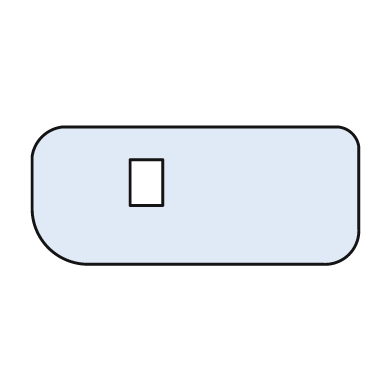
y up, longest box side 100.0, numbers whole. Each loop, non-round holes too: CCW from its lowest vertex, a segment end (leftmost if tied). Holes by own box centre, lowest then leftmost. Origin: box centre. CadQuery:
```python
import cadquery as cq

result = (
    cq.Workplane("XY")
    .moveTo(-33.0, -21.0)
    .lineTo(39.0, -21.0)
    .threePointArc((47.0, -18.0), (50.0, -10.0))
    .lineTo(50.0, 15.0)
    .threePointArc((48.0, 19.0), (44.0, 21.0))
    .lineTo(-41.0, 21.0)
    .threePointArc((-47.0, 18.0), (-50.0, 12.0))
    .lineTo(-50.0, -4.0)
    .threePointArc((-45.0, -16.0), (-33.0, -21.0))
    .close()
    .moveTo(-20.0, -3.0)
    .lineTo(-10.0, -3.0)
    .lineTo(-10.0, 11.0)
    .lineTo(-20.0, 11.0)
    .close()
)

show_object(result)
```